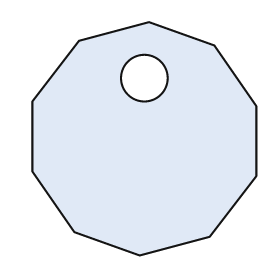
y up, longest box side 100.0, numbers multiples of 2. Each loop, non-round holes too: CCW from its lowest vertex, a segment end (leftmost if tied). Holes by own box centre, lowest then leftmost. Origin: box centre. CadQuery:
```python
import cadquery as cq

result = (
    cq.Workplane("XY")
    .moveTo(-2.0, -50.0)
    .lineTo(28.0, -42.0)
    .lineTo(48.0, -16.0)
    .lineTo(48.0, 14.0)
    .lineTo(30.0, 40.0)
    .lineTo(2.0, 50.0)
    .lineTo(-28.0, 42.0)
    .lineTo(-48.0, 16.0)
    .lineTo(-48.0, -14.0)
    .lineTo(-30.0, -40.0)
    .close()
    .moveTo(0.0, 26.0)
    .circle(10.0)
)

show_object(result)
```